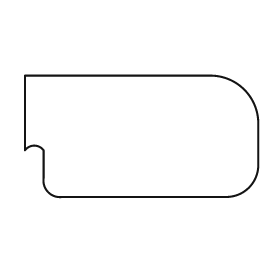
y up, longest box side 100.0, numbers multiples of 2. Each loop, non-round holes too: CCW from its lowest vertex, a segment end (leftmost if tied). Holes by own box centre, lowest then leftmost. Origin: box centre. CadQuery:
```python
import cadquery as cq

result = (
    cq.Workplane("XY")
    .moveTo(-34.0, -26.0)
    .lineTo(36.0, -26.0)
    .threePointArc((46.0, -22.0), (50.0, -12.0))
    .lineTo(50.0, 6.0)
    .threePointArc((44.0, 20.0), (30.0, 26.0))
    .lineTo(-50.0, 26.0)
    .lineTo(-50.0, -6.0)
    .threePointArc((-46.0, -4.0), (-42.0, -6.0))
    .lineTo(-42.0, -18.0)
    .threePointArc((-40.0, -24.0), (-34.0, -26.0))
    .close()
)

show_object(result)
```